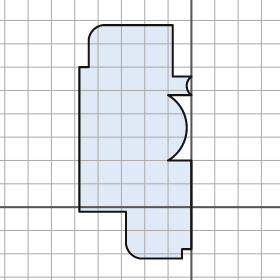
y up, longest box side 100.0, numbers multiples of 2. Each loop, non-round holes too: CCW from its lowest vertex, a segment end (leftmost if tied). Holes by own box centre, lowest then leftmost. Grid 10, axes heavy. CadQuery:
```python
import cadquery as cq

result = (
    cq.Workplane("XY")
    .moveTo(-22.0, -22.0)
    .lineTo(-4.0, -22.0)
    .lineTo(-4.0, -18.0)
    .lineTo(0.0, -18.0)
    .lineTo(0.0, 20.0)
    .lineTo(-10.0, 20.0)
    .threePointArc((-2.0, 34.0), (-10.0, 48.0))
    .lineTo(0.0, 48.0)
    .threePointArc((-2.0, 52.0), (0.0, 56.0))
    .lineTo(-8.0, 56.0)
    .lineTo(-8.0, 78.0)
    .lineTo(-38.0, 78.0)
    .threePointArc((-42.0, 76.0), (-44.0, 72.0))
    .lineTo(-44.0, 60.0)
    .lineTo(-48.0, 60.0)
    .lineTo(-48.0, -2.0)
    .lineTo(-28.0, -2.0)
    .lineTo(-28.0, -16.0)
    .threePointArc((-26.0, -20.0), (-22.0, -22.0))
    .close()
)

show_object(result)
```